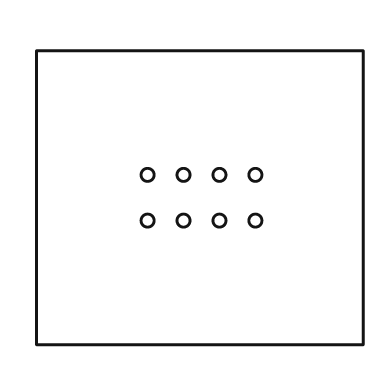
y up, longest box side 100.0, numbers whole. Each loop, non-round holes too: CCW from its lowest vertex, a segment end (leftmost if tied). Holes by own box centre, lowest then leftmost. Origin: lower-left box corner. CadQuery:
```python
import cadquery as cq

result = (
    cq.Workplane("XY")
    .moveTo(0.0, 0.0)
    .lineTo(100.0, 0.0)
    .lineTo(100.0, 90.0)
    .lineTo(0.0, 90.0)
    .close()
    .moveTo(34.0, 38.0)
    .circle(2.0)
    .moveTo(45.0, 38.0)
    .circle(2.0)
    .moveTo(56.0, 38.0)
    .circle(2.0)
    .moveTo(67.0, 38.0)
    .circle(2.0)
    .moveTo(34.0, 52.0)
    .circle(2.0)
    .moveTo(45.0, 52.0)
    .circle(2.0)
    .moveTo(56.0, 52.0)
    .circle(2.0)
    .moveTo(67.0, 52.0)
    .circle(2.0)
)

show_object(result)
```